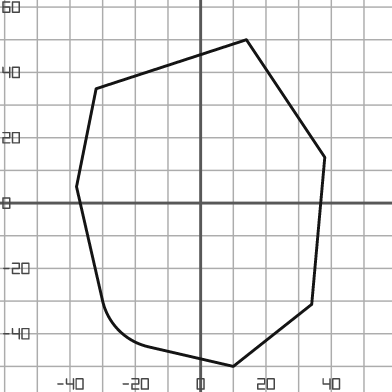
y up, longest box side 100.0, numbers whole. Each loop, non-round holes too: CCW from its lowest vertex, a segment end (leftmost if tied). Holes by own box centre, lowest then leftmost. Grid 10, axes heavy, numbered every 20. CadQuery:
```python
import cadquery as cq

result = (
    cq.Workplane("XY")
    .moveTo(10.0, -50.0)
    .lineTo(34.0, -31.0)
    .lineTo(38.0, 14.0)
    .lineTo(14.0, 50.0)
    .lineTo(-32.0, 35.0)
    .lineTo(-38.0, 5.0)
    .lineTo(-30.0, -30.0)
    .threePointArc((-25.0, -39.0), (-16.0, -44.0))
    .close()
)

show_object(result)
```